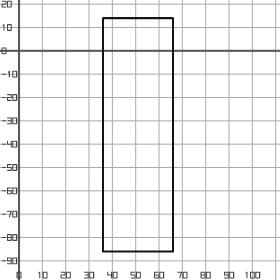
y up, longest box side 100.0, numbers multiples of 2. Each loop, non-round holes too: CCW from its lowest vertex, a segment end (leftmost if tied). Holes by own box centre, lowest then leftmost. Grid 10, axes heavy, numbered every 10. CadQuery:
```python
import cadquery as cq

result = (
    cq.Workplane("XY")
    .moveTo(36.0, -86.0)
    .lineTo(66.0, -86.0)
    .lineTo(66.0, 14.0)
    .lineTo(36.0, 14.0)
    .close()
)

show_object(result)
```